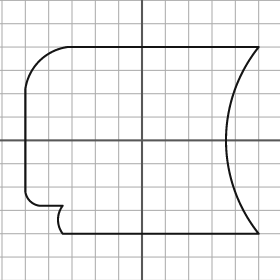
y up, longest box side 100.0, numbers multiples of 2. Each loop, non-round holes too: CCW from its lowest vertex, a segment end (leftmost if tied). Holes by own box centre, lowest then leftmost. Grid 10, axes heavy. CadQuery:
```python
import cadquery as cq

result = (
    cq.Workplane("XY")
    .moveTo(-34.0, -40.0)
    .lineTo(50.0, -40.0)
    .threePointArc((36.0, 0.0), (50.0, 40.0))
    .lineTo(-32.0, 40.0)
    .threePointArc((-44.0, 34.0), (-50.0, 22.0))
    .lineTo(-50.0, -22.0)
    .threePointArc((-48.0, -26.0), (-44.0, -28.0))
    .lineTo(-34.0, -28.0)
    .threePointArc((-36.0, -34.0), (-34.0, -40.0))
    .close()
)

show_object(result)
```